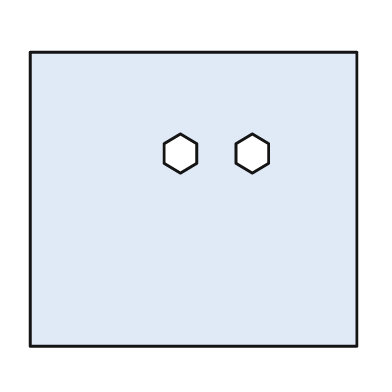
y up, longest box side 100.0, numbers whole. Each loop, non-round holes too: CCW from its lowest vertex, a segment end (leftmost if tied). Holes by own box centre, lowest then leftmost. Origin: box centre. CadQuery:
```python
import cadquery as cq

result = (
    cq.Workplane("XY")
    .moveTo(-50.0, -45.0)
    .lineTo(50.0, -45.0)
    .lineTo(50.0, 45.0)
    .lineTo(-50.0, 45.0)
    .close()
    .moveTo(-4.0, 8.0)
    .lineTo(1.0, 11.0)
    .lineTo(1.0, 17.0)
    .lineTo(-4.0, 20.0)
    .lineTo(-9.0, 17.0)
    .lineTo(-9.0, 11.0)
    .close()
    .moveTo(18.0, 8.0)
    .lineTo(23.0, 11.0)
    .lineTo(23.0, 17.0)
    .lineTo(18.0, 20.0)
    .lineTo(13.0, 17.0)
    .lineTo(13.0, 11.0)
    .close()
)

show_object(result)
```